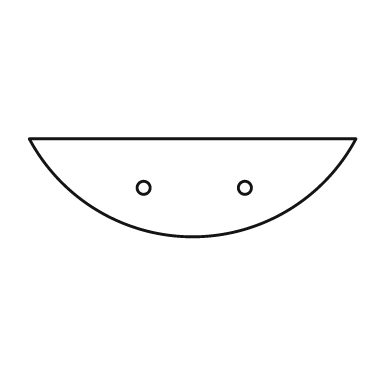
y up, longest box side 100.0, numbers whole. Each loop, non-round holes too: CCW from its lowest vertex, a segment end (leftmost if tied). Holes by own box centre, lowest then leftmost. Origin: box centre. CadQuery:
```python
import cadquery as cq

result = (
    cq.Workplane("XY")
    .moveTo(-50.0, 15.0)
    .threePointArc((0.0, -15.0), (50.0, 15.0))
    .close()
    .moveTo(-15.0, 0.0)
    .circle(2.0)
    .moveTo(16.0, 0.0)
    .circle(2.0)
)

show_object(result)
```